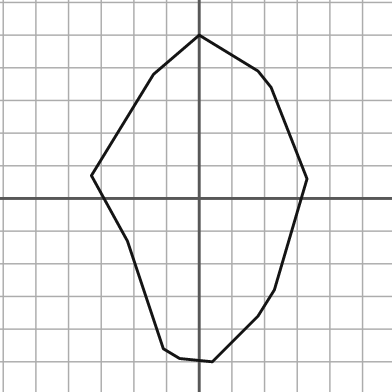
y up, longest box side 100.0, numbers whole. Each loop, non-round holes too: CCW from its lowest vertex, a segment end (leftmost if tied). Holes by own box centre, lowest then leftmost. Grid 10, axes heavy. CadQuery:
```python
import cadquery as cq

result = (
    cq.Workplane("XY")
    .moveTo(4.0, -50.0)
    .lineTo(18.0, -36.0)
    .lineTo(23.0, -28.0)
    .lineTo(33.0, 6.0)
    .lineTo(22.0, 34.0)
    .lineTo(18.0, 39.0)
    .lineTo(0.0, 50.0)
    .lineTo(-14.0, 38.0)
    .lineTo(-33.0, 7.0)
    .lineTo(-22.0, -13.0)
    .lineTo(-11.0, -46.0)
    .lineTo(-6.0, -49.0)
    .close()
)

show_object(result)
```